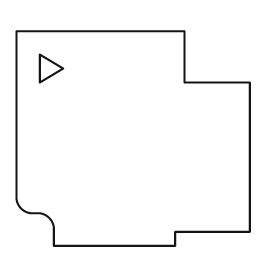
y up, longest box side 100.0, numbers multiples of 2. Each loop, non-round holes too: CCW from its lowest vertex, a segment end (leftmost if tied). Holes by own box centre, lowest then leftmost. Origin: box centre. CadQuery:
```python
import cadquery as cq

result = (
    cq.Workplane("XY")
    .moveTo(-34.0, -46.0)
    .lineTo(18.0, -46.0)
    .lineTo(18.0, -40.0)
    .lineTo(50.0, -40.0)
    .lineTo(50.0, 24.0)
    .lineTo(22.0, 24.0)
    .lineTo(22.0, 46.0)
    .lineTo(-50.0, 46.0)
    .lineTo(-50.0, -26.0)
    .threePointArc((-48.0, -30.0), (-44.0, -32.0))
    .lineTo(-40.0, -32.0)
    .threePointArc((-36.0, -34.0), (-34.0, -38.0))
    .close()
    .moveTo(-40.0, 24.0)
    .lineTo(-30.0, 30.0)
    .lineTo(-40.0, 36.0)
    .close()
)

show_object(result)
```